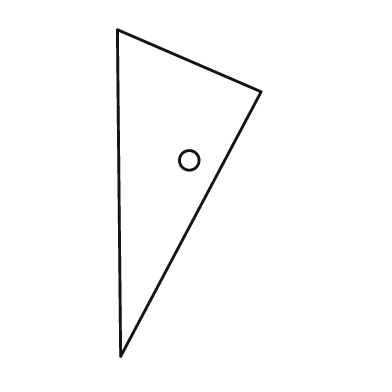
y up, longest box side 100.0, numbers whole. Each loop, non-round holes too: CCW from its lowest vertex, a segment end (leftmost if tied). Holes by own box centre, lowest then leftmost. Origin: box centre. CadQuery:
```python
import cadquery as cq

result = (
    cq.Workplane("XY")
    .moveTo(-21.0, -50.0)
    .lineTo(22.0, 31.0)
    .lineTo(-22.0, 50.0)
    .close()
    .moveTo(0.0, 10.0)
    .circle(3.0)
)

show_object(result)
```